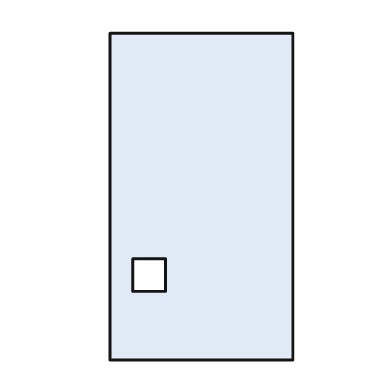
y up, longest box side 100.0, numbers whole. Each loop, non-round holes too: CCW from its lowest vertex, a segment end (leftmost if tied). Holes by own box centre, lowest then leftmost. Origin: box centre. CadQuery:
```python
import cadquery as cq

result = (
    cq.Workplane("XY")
    .moveTo(-28.0, -50.0)
    .lineTo(28.0, -50.0)
    .lineTo(28.0, 50.0)
    .lineTo(-28.0, 50.0)
    .close()
    .moveTo(-21.0, -29.0)
    .lineTo(-11.0, -29.0)
    .lineTo(-11.0, -19.0)
    .lineTo(-21.0, -19.0)
    .close()
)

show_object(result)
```